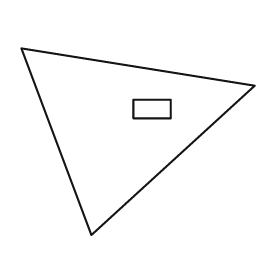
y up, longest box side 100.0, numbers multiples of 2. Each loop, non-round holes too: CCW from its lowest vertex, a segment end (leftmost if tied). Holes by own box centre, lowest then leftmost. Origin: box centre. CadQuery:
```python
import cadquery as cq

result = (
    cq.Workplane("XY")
    .moveTo(-20.0, -40.0)
    .lineTo(50.0, 24.0)
    .lineTo(-50.0, 40.0)
    .close()
    .moveTo(-2.0, 10.0)
    .lineTo(14.0, 10.0)
    .lineTo(14.0, 18.0)
    .lineTo(-2.0, 18.0)
    .close()
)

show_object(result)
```